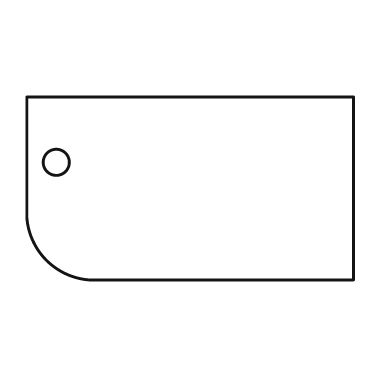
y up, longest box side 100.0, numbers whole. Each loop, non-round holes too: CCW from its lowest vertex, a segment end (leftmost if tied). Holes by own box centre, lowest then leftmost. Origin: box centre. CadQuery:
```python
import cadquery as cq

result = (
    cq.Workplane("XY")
    .moveTo(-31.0, -28.0)
    .lineTo(50.0, -28.0)
    .lineTo(50.0, 28.0)
    .lineTo(-50.0, 28.0)
    .lineTo(-50.0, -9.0)
    .threePointArc((-44.0, -22.0), (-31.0, -28.0))
    .close()
    .moveTo(-41.0, 8.0)
    .circle(4.0)
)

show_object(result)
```